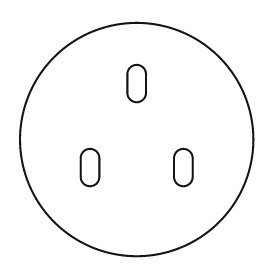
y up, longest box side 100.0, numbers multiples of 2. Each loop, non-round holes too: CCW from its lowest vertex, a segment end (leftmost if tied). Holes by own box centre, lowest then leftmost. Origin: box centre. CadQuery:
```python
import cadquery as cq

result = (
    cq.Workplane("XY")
    .moveTo(0.0, 0.0)
    .circle(50.0)
    .moveTo(-24.0, -16.0)
    .threePointArc((-20.0, -20.0), (-16.0, -16.0))
    .lineTo(-16.0, -8.0)
    .threePointArc((-20.0, -4.0), (-24.0, -8.0))
    .close()
    .moveTo(16.0, -16.0)
    .threePointArc((20.0, -20.0), (24.0, -16.0))
    .lineTo(24.0, -8.0)
    .threePointArc((20.0, -4.0), (16.0, -8.0))
    .close()
    .moveTo(-4.0, 20.0)
    .threePointArc((0.0, 16.0), (4.0, 20.0))
    .lineTo(4.0, 28.0)
    .threePointArc((0.0, 32.0), (-4.0, 28.0))
    .close()
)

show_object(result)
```